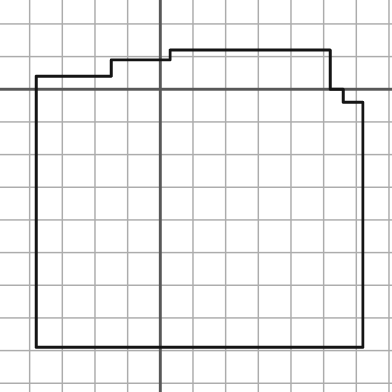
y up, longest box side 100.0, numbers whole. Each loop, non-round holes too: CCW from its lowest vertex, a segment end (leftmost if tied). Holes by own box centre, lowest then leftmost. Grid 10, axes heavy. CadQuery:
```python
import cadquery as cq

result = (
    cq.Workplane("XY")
    .moveTo(-38.0, -79.0)
    .lineTo(62.0, -79.0)
    .lineTo(62.0, -4.0)
    .lineTo(56.0, -4.0)
    .lineTo(56.0, 0.0)
    .lineTo(52.0, 0.0)
    .lineTo(52.0, 12.0)
    .lineTo(3.0, 12.0)
    .lineTo(3.0, 9.0)
    .lineTo(-15.0, 9.0)
    .lineTo(-15.0, 4.0)
    .lineTo(-38.0, 4.0)
    .close()
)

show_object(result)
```